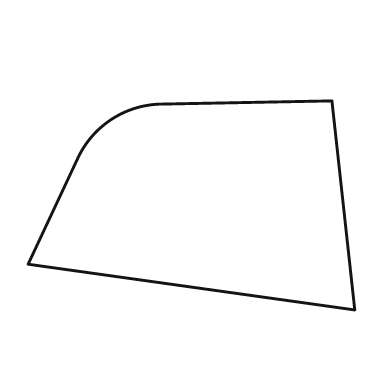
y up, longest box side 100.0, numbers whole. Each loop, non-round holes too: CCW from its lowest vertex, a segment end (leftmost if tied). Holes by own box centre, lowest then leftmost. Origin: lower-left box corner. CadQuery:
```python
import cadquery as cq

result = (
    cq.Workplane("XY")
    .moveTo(100.0, 0.0)
    .lineTo(93.0, 64.0)
    .lineTo(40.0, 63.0)
    .threePointArc((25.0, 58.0), (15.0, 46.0))
    .lineTo(0.0, 14.0)
    .close()
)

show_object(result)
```